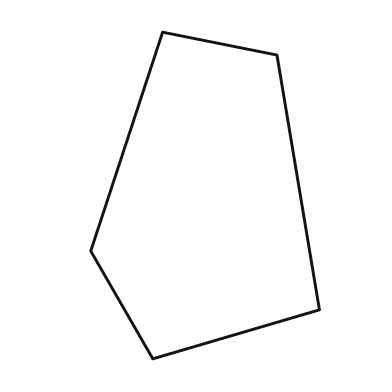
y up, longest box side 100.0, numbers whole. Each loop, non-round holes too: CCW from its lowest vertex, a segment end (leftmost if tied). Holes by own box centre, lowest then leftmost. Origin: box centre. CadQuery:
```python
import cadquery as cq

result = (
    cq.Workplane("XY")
    .moveTo(-16.0, -50.0)
    .lineTo(35.0, -35.0)
    .lineTo(22.0, 43.0)
    .lineTo(-13.0, 50.0)
    .lineTo(-35.0, -17.0)
    .close()
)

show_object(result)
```